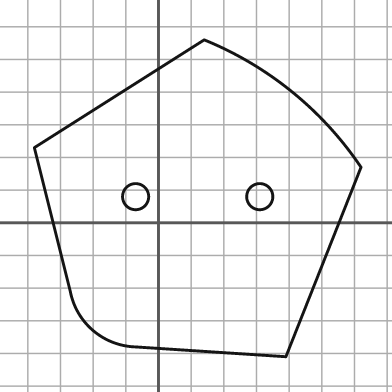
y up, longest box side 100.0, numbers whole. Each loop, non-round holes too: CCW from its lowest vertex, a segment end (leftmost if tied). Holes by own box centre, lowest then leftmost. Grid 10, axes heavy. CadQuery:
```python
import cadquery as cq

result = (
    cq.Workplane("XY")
    .moveTo(39.0, -41.0)
    .lineTo(62.0, 17.0)
    .threePointArc((41.0, 40.0), (14.0, 56.0))
    .lineTo(-38.0, 23.0)
    .lineTo(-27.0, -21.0)
    .threePointArc((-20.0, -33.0), (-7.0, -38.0))
    .close()
    .moveTo(-7.0, 8.0)
    .circle(4.0)
    .moveTo(31.0, 8.0)
    .circle(4.0)
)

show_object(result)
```